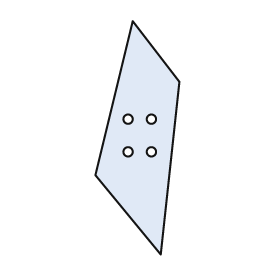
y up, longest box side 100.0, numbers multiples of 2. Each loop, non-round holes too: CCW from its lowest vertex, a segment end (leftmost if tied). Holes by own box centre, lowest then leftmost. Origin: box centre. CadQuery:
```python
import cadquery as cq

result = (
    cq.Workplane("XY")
    .moveTo(10.0, -50.0)
    .lineTo(18.0, 24.0)
    .lineTo(-2.0, 50.0)
    .lineTo(-18.0, -16.0)
    .close()
    .moveTo(-4.0, -6.0)
    .circle(2.0)
    .moveTo(6.0, -6.0)
    .circle(2.0)
    .moveTo(-4.0, 8.0)
    .circle(2.0)
    .moveTo(6.0, 8.0)
    .circle(2.0)
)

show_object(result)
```